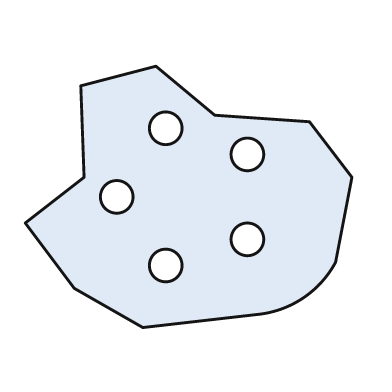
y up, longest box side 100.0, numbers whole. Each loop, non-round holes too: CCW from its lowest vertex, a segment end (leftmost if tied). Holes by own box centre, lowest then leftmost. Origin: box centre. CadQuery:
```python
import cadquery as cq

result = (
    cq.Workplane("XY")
    .moveTo(-14.0, -40.0)
    .lineTo(21.0, -36.0)
    .threePointArc((35.0, -31.0), (45.0, -20.0))
    .lineTo(50.0, 6.0)
    .lineTo(37.0, 23.0)
    .lineTo(8.0, 25.0)
    .lineTo(-10.0, 40.0)
    .lineTo(-33.0, 34.0)
    .lineTo(-32.0, 6.0)
    .lineTo(-50.0, -8.0)
    .lineTo(-35.0, -28.0)
    .close()
    .moveTo(-7.0, -21.0)
    .circle(5.0)
    .moveTo(18.0, -13.0)
    .circle(5.0)
    .moveTo(-22.0, 0.0)
    .circle(5.0)
    .moveTo(18.0, 13.0)
    .circle(5.0)
    .moveTo(-7.0, 21.0)
    .circle(5.0)
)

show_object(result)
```